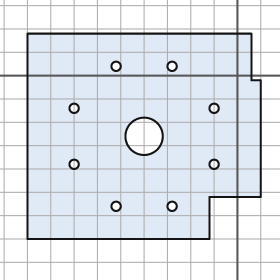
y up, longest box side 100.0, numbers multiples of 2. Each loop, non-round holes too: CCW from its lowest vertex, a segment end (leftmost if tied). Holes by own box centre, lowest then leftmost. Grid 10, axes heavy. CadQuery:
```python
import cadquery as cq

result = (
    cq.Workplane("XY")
    .moveTo(-90.0, -70.0)
    .lineTo(-12.0, -70.0)
    .lineTo(-12.0, -52.0)
    .lineTo(10.0, -52.0)
    .lineTo(10.0, -2.0)
    .lineTo(6.0, -2.0)
    .lineTo(6.0, 18.0)
    .lineTo(-90.0, 18.0)
    .close()
    .moveTo(-52.0, -56.0)
    .circle(2.0)
    .moveTo(-28.0, -56.0)
    .circle(2.0)
    .moveTo(-70.0, -38.0)
    .circle(2.0)
    .moveTo(-10.0, -38.0)
    .circle(2.0)
    .moveTo(-40.0, -26.0)
    .circle(8.0)
    .moveTo(-70.0, -14.0)
    .circle(2.0)
    .moveTo(-10.0, -14.0)
    .circle(2.0)
    .moveTo(-52.0, 4.0)
    .circle(2.0)
    .moveTo(-28.0, 4.0)
    .circle(2.0)
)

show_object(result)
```